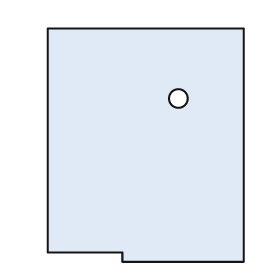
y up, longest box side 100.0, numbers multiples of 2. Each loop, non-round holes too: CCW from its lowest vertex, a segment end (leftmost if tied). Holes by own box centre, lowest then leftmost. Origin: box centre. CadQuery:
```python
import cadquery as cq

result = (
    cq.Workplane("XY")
    .moveTo(-10.0, -50.0)
    .lineTo(42.0, -50.0)
    .lineTo(42.0, 50.0)
    .lineTo(-42.0, 50.0)
    .lineTo(-42.0, -46.0)
    .lineTo(-10.0, -46.0)
    .close()
    .moveTo(14.0, 20.0)
    .circle(4.0)
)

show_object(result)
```